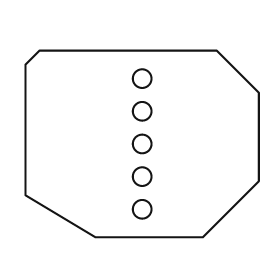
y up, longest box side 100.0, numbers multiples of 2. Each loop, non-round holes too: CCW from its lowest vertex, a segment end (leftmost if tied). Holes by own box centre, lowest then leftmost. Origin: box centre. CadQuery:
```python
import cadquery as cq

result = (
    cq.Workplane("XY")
    .moveTo(-20.0, -40.0)
    .lineTo(26.0, -40.0)
    .lineTo(50.0, -16.0)
    .lineTo(50.0, 22.0)
    .lineTo(32.0, 40.0)
    .lineTo(-44.0, 40.0)
    .lineTo(-50.0, 34.0)
    .lineTo(-50.0, -22.0)
    .close()
    .moveTo(0.0, -28.0)
    .circle(4.0)
    .moveTo(0.0, -14.0)
    .circle(4.0)
    .moveTo(0.0, 0.0)
    .circle(4.0)
    .moveTo(0.0, 14.0)
    .circle(4.0)
    .moveTo(0.0, 28.0)
    .circle(4.0)
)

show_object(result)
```